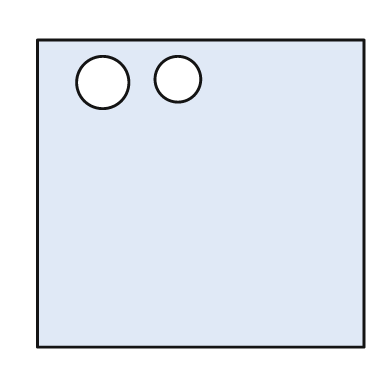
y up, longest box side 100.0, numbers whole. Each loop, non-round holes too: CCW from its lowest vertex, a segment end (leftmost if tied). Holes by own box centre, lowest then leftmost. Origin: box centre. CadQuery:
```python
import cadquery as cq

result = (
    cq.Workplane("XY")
    .moveTo(-50.0, -47.0)
    .lineTo(50.0, -47.0)
    .lineTo(50.0, 47.0)
    .lineTo(-50.0, 47.0)
    .close()
    .moveTo(-30.0, 34.0)
    .circle(8.0)
    .moveTo(-7.0, 35.0)
    .circle(7.0)
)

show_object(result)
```